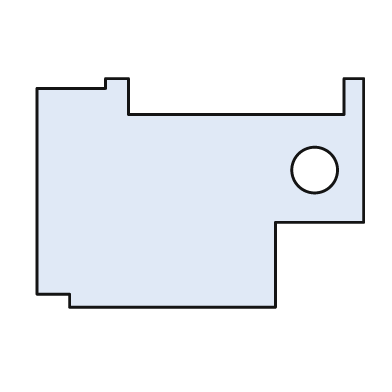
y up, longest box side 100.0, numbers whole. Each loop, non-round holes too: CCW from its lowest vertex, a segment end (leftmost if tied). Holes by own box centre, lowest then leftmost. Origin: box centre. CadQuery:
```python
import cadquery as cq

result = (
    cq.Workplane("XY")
    .moveTo(-40.0, -35.0)
    .lineTo(23.0, -35.0)
    .lineTo(23.0, -9.0)
    .lineTo(50.0, -9.0)
    .lineTo(50.0, 35.0)
    .lineTo(44.0, 35.0)
    .lineTo(44.0, 24.0)
    .lineTo(-22.0, 24.0)
    .lineTo(-22.0, 35.0)
    .lineTo(-29.0, 35.0)
    .lineTo(-29.0, 32.0)
    .lineTo(-50.0, 32.0)
    .lineTo(-50.0, -31.0)
    .lineTo(-40.0, -31.0)
    .close()
    .moveTo(35.0, 7.0)
    .circle(7.0)
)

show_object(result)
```